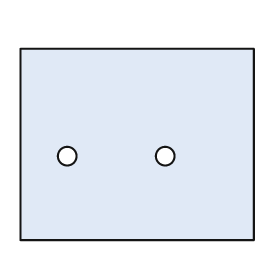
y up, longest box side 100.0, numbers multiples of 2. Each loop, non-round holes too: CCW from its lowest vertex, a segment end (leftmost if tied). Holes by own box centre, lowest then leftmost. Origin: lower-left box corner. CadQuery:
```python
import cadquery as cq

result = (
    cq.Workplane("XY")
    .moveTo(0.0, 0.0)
    .lineTo(100.0, 0.0)
    .lineTo(100.0, 82.0)
    .lineTo(0.0, 82.0)
    .close()
    .moveTo(20.0, 36.0)
    .circle(4.0)
    .moveTo(62.0, 36.0)
    .circle(4.0)
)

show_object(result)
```